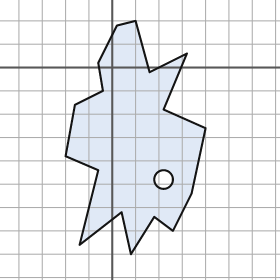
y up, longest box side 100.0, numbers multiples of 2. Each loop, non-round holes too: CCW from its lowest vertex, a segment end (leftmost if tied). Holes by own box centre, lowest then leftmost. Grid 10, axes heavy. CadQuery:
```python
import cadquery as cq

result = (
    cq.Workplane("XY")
    .moveTo(8.0, -80.0)
    .lineTo(18.0, -64.0)
    .lineTo(26.0, -70.0)
    .lineTo(34.0, -54.0)
    .lineTo(40.0, -26.0)
    .lineTo(22.0, -18.0)
    .lineTo(32.0, 6.0)
    .lineTo(16.0, -2.0)
    .lineTo(10.0, 20.0)
    .lineTo(2.0, 18.0)
    .lineTo(-6.0, 2.0)
    .lineTo(-4.0, -10.0)
    .lineTo(-16.0, -16.0)
    .lineTo(-20.0, -38.0)
    .lineTo(-6.0, -44.0)
    .lineTo(-14.0, -76.0)
    .lineTo(4.0, -62.0)
    .close()
    .moveTo(22.0, -48.0)
    .circle(4.0)
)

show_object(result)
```